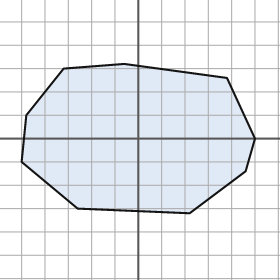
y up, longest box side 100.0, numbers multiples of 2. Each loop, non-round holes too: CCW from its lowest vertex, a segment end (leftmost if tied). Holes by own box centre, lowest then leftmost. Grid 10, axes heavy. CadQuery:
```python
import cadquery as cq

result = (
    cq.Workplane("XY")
    .moveTo(22.0, -32.0)
    .lineTo(46.0, -14.0)
    .lineTo(50.0, 0.0)
    .lineTo(38.0, 26.0)
    .lineTo(-6.0, 32.0)
    .lineTo(-32.0, 30.0)
    .lineTo(-48.0, 10.0)
    .lineTo(-50.0, -10.0)
    .lineTo(-26.0, -30.0)
    .close()
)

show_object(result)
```